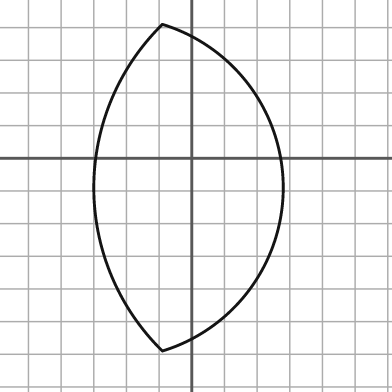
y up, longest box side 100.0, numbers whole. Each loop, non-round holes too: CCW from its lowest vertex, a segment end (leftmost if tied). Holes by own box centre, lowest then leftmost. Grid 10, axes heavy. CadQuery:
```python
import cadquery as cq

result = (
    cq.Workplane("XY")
    .moveTo(-9.0, -59.0)
    .threePointArc((28.0, -9.0), (-9.0, 41.0))
    .threePointArc((-30.0, -9.0), (-9.0, -59.0))
    .close()
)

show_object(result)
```